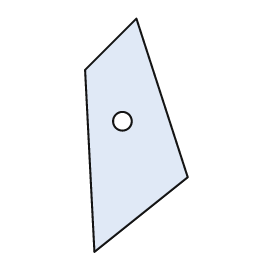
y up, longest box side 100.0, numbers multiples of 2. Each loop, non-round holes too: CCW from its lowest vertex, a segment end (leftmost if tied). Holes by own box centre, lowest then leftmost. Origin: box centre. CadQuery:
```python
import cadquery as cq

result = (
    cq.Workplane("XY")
    .moveTo(-18.0, -50.0)
    .lineTo(22.0, -18.0)
    .lineTo(0.0, 50.0)
    .lineTo(-22.0, 28.0)
    .close()
    .moveTo(-6.0, 6.0)
    .circle(4.0)
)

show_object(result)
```